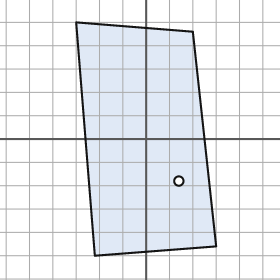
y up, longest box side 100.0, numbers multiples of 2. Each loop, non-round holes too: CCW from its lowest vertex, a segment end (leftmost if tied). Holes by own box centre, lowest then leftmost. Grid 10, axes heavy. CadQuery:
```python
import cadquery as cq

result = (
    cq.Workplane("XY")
    .moveTo(-22.0, -50.0)
    .lineTo(30.0, -46.0)
    .lineTo(20.0, 46.0)
    .lineTo(-30.0, 50.0)
    .close()
    .moveTo(14.0, -18.0)
    .circle(2.0)
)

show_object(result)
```